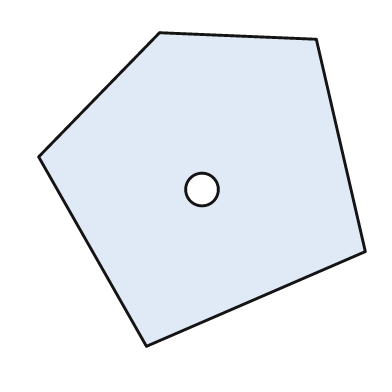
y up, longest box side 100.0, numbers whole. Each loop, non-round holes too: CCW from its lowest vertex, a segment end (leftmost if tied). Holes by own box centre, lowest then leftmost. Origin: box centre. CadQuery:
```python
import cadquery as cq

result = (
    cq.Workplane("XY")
    .moveTo(-17.0, -48.0)
    .lineTo(50.0, -19.0)
    .lineTo(35.0, 46.0)
    .lineTo(-13.0, 48.0)
    .lineTo(-50.0, 10.0)
    .close()
    .moveTo(0.0, 0.0)
    .circle(5.0)
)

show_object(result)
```